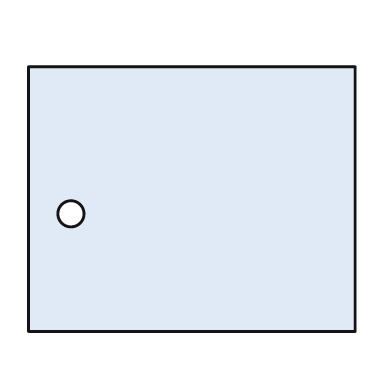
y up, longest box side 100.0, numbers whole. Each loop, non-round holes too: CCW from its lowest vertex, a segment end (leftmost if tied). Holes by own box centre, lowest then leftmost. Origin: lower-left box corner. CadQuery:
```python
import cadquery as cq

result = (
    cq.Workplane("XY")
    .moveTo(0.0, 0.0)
    .lineTo(100.0, 0.0)
    .lineTo(100.0, 81.0)
    .lineTo(0.0, 81.0)
    .close()
    .moveTo(13.0, 36.0)
    .circle(4.0)
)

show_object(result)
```